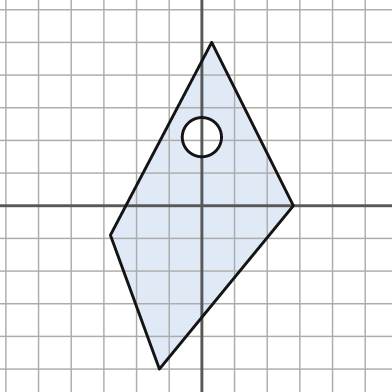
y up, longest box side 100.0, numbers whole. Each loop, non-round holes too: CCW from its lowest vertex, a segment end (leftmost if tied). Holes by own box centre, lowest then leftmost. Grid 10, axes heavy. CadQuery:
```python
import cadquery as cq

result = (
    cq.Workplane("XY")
    .moveTo(-13.0, -50.0)
    .lineTo(28.0, 0.0)
    .lineTo(3.0, 50.0)
    .lineTo(-28.0, -9.0)
    .close()
    .moveTo(0.0, 21.0)
    .circle(6.0)
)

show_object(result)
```